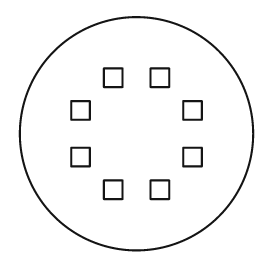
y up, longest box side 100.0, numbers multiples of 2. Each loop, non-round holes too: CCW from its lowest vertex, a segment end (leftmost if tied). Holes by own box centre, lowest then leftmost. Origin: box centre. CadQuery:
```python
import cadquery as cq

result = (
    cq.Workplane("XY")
    .moveTo(0.0, 0.0)
    .circle(50.0)
    .moveTo(-14.0, -28.0)
    .lineTo(-6.0, -28.0)
    .lineTo(-6.0, -20.0)
    .lineTo(-14.0, -20.0)
    .close()
    .moveTo(6.0, -28.0)
    .lineTo(14.0, -28.0)
    .lineTo(14.0, -20.0)
    .lineTo(6.0, -20.0)
    .close()
    .moveTo(-28.0, -14.0)
    .lineTo(-20.0, -14.0)
    .lineTo(-20.0, -6.0)
    .lineTo(-28.0, -6.0)
    .close()
    .moveTo(20.0, -14.0)
    .lineTo(28.0, -14.0)
    .lineTo(28.0, -6.0)
    .lineTo(20.0, -6.0)
    .close()
    .moveTo(-28.0, 6.0)
    .lineTo(-20.0, 6.0)
    .lineTo(-20.0, 14.0)
    .lineTo(-28.0, 14.0)
    .close()
    .moveTo(20.0, 6.0)
    .lineTo(28.0, 6.0)
    .lineTo(28.0, 14.0)
    .lineTo(20.0, 14.0)
    .close()
    .moveTo(-14.0, 20.0)
    .lineTo(-6.0, 20.0)
    .lineTo(-6.0, 28.0)
    .lineTo(-14.0, 28.0)
    .close()
    .moveTo(6.0, 20.0)
    .lineTo(14.0, 20.0)
    .lineTo(14.0, 28.0)
    .lineTo(6.0, 28.0)
    .close()
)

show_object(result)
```